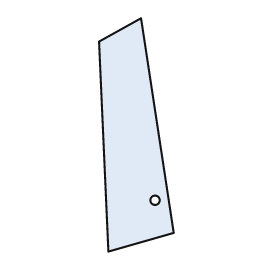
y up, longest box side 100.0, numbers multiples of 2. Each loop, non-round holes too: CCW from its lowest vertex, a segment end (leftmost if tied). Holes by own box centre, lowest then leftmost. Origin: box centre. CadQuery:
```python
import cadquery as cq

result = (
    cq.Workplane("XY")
    .moveTo(-12.0, -50.0)
    .lineTo(16.0, -42.0)
    .lineTo(2.0, 50.0)
    .lineTo(-16.0, 40.0)
    .close()
    .moveTo(8.0, -28.0)
    .circle(2.0)
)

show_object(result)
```